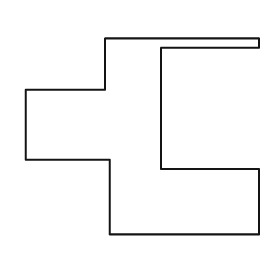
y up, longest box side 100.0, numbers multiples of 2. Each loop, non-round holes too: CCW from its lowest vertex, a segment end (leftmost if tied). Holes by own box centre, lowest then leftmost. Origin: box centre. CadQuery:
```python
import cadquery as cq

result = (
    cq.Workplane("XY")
    .moveTo(-14.0, -42.0)
    .lineTo(50.0, -42.0)
    .lineTo(50.0, -14.0)
    .lineTo(8.0, -14.0)
    .lineTo(8.0, 38.0)
    .lineTo(50.0, 38.0)
    .lineTo(50.0, 42.0)
    .lineTo(-16.0, 42.0)
    .lineTo(-16.0, 20.0)
    .lineTo(-50.0, 20.0)
    .lineTo(-50.0, -10.0)
    .lineTo(-14.0, -10.0)
    .close()
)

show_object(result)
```